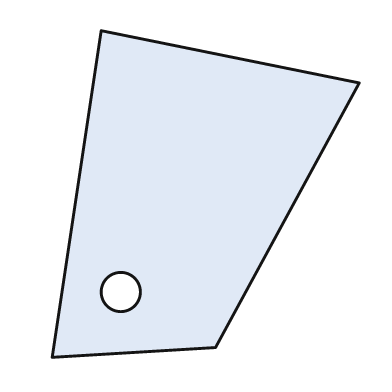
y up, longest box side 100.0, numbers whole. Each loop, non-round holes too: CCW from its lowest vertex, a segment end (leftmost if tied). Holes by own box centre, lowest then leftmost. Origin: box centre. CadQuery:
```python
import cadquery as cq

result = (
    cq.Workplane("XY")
    .moveTo(-47.0, -50.0)
    .lineTo(3.0, -47.0)
    .lineTo(47.0, 34.0)
    .lineTo(-32.0, 50.0)
    .close()
    .moveTo(-26.0, -30.0)
    .circle(6.0)
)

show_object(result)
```